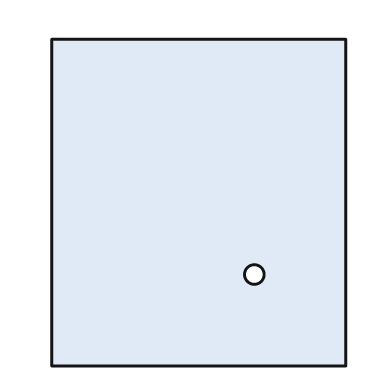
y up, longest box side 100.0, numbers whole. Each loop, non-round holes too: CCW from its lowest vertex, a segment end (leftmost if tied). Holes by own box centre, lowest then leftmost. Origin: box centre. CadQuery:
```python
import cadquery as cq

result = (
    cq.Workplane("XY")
    .moveTo(-45.0, -50.0)
    .lineTo(45.0, -50.0)
    .lineTo(45.0, 50.0)
    .lineTo(-45.0, 50.0)
    .close()
    .moveTo(17.0, -22.0)
    .circle(3.0)
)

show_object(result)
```